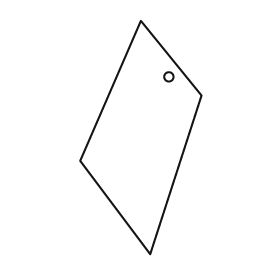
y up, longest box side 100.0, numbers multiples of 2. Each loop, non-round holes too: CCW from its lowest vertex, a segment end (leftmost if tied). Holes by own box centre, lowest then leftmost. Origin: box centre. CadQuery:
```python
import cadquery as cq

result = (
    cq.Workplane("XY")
    .moveTo(4.0, -50.0)
    .lineTo(26.0, 18.0)
    .lineTo(0.0, 50.0)
    .lineTo(-26.0, -10.0)
    .close()
    .moveTo(12.0, 26.0)
    .circle(2.0)
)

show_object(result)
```